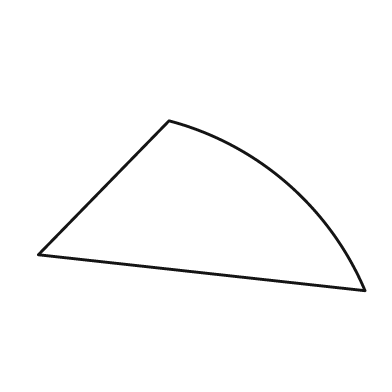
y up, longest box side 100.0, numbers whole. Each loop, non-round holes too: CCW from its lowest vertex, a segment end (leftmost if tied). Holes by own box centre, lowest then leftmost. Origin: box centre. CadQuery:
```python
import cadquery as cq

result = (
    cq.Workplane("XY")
    .moveTo(50.0, -26.0)
    .threePointArc((26.0, 7.0), (-10.0, 26.0))
    .lineTo(-50.0, -15.0)
    .close()
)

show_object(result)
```